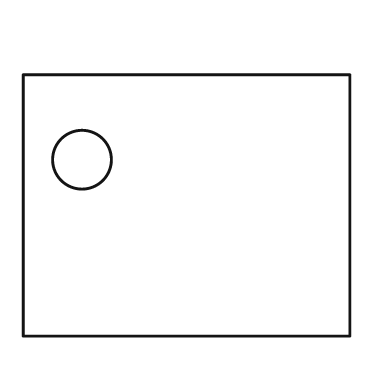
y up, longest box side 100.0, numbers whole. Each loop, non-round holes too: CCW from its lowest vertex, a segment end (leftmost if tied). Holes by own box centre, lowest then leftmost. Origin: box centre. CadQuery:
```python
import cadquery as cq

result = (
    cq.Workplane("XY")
    .moveTo(-50.0, -40.0)
    .lineTo(50.0, -40.0)
    .lineTo(50.0, 40.0)
    .lineTo(-50.0, 40.0)
    .close()
    .moveTo(-32.0, 14.0)
    .circle(9.0)
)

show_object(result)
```